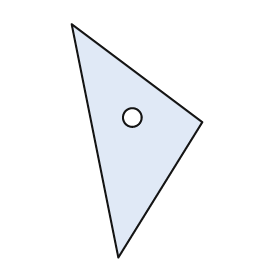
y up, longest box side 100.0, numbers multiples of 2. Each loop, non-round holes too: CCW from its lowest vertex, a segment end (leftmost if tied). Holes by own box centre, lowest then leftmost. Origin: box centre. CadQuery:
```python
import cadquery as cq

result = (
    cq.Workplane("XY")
    .moveTo(-8.0, -50.0)
    .lineTo(28.0, 8.0)
    .lineTo(-28.0, 50.0)
    .close()
    .moveTo(-2.0, 10.0)
    .circle(4.0)
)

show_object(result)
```